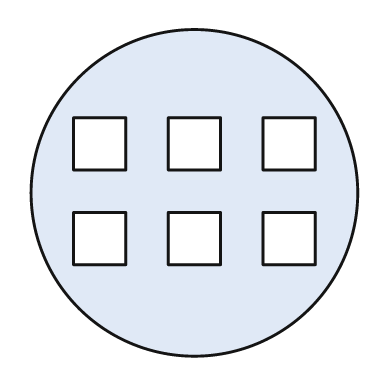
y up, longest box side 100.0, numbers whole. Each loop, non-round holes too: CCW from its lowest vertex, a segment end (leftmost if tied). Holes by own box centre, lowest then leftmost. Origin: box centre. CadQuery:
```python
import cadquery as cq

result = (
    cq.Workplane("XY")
    .moveTo(0.0, 0.0)
    .circle(50.0)
    .moveTo(-37.0, -22.0)
    .lineTo(-21.0, -22.0)
    .lineTo(-21.0, -6.0)
    .lineTo(-37.0, -6.0)
    .close()
    .moveTo(-8.0, -22.0)
    .lineTo(8.0, -22.0)
    .lineTo(8.0, -6.0)
    .lineTo(-8.0, -6.0)
    .close()
    .moveTo(21.0, -22.0)
    .lineTo(37.0, -22.0)
    .lineTo(37.0, -6.0)
    .lineTo(21.0, -6.0)
    .close()
    .moveTo(-37.0, 7.0)
    .lineTo(-21.0, 7.0)
    .lineTo(-21.0, 23.0)
    .lineTo(-37.0, 23.0)
    .close()
    .moveTo(-8.0, 7.0)
    .lineTo(8.0, 7.0)
    .lineTo(8.0, 23.0)
    .lineTo(-8.0, 23.0)
    .close()
    .moveTo(21.0, 7.0)
    .lineTo(37.0, 7.0)
    .lineTo(37.0, 23.0)
    .lineTo(21.0, 23.0)
    .close()
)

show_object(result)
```